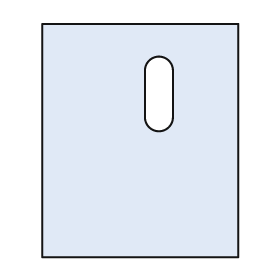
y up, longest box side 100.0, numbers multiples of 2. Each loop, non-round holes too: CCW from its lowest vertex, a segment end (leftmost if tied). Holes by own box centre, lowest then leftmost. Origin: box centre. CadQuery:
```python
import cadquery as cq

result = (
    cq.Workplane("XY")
    .moveTo(-42.0, -50.0)
    .lineTo(42.0, -50.0)
    .lineTo(42.0, 50.0)
    .lineTo(-42.0, 50.0)
    .close()
    .moveTo(2.0, 10.0)
    .threePointArc((8.0, 4.0), (14.0, 10.0))
    .lineTo(14.0, 30.0)
    .threePointArc((8.0, 36.0), (2.0, 30.0))
    .close()
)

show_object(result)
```